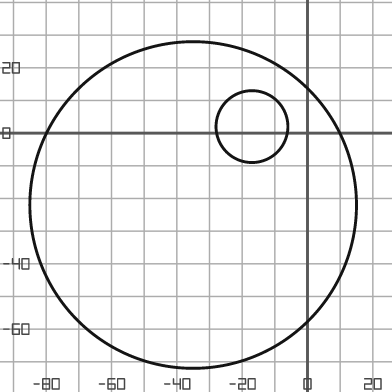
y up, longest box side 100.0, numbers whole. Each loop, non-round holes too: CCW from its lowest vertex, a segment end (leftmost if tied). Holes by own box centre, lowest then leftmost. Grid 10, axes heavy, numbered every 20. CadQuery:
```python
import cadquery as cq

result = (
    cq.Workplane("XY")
    .moveTo(-35.0, -22.0)
    .circle(50.0)
    .moveTo(-17.0, 2.0)
    .circle(11.0)
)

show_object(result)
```